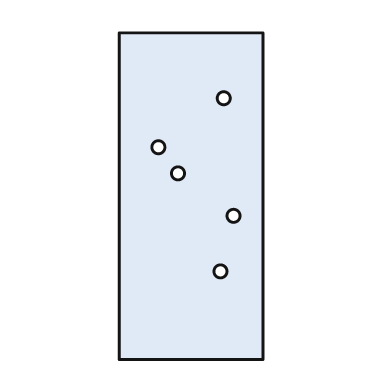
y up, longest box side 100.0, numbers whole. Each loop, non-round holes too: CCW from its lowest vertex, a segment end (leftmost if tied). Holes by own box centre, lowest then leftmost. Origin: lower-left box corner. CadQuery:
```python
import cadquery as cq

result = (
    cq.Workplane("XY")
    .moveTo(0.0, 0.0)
    .lineTo(44.0, 0.0)
    .lineTo(44.0, 100.0)
    .lineTo(0.0, 100.0)
    .close()
    .moveTo(31.0, 27.0)
    .circle(2.0)
    .moveTo(35.0, 44.0)
    .circle(2.0)
    .moveTo(18.0, 57.0)
    .circle(2.0)
    .moveTo(12.0, 65.0)
    .circle(2.0)
    .moveTo(32.0, 80.0)
    .circle(2.0)
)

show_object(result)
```